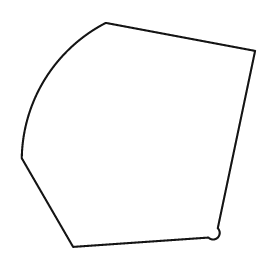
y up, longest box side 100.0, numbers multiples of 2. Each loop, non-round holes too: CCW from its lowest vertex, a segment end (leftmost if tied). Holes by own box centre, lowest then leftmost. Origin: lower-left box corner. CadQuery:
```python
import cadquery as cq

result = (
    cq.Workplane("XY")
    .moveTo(22.0, 0.0)
    .lineTo(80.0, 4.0)
    .threePointArc((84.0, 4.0), (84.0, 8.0))
    .lineTo(100.0, 84.0)
    .lineTo(36.0, 96.0)
    .threePointArc((10.0, 72.0), (0.0, 38.0))
    .close()
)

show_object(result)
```